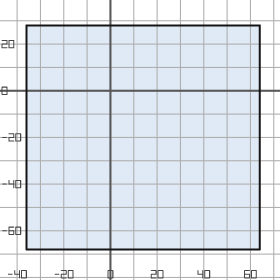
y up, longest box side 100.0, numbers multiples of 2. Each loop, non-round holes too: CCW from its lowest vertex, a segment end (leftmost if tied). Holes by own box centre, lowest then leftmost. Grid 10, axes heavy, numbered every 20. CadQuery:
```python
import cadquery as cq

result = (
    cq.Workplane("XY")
    .moveTo(-36.0, -68.0)
    .lineTo(64.0, -68.0)
    .lineTo(64.0, 28.0)
    .lineTo(-36.0, 28.0)
    .close()
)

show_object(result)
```